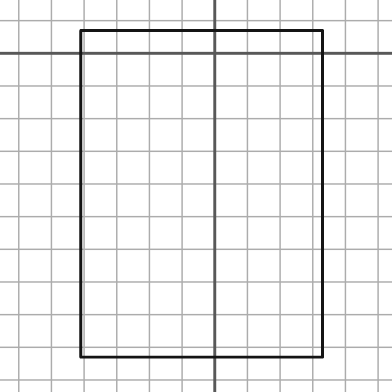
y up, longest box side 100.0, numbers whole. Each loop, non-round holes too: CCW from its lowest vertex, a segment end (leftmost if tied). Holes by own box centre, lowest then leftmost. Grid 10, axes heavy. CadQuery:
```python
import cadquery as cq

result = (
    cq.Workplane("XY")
    .moveTo(-41.0, -93.0)
    .lineTo(33.0, -93.0)
    .lineTo(33.0, 7.0)
    .lineTo(-41.0, 7.0)
    .close()
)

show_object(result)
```